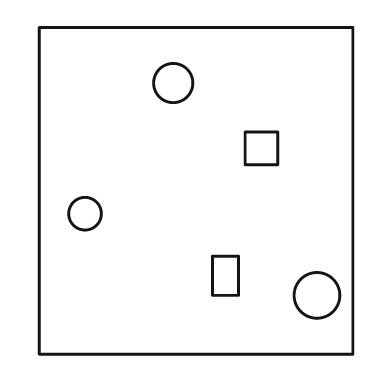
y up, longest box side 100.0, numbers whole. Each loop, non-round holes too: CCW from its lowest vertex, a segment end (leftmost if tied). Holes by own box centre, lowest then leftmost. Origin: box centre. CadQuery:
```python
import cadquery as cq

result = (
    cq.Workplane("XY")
    .moveTo(-48.0, -50.0)
    .lineTo(48.0, -50.0)
    .lineTo(48.0, 50.0)
    .lineTo(-48.0, 50.0)
    .close()
    .moveTo(37.0, -32.0)
    .circle(7.0)
    .moveTo(5.0, -32.0)
    .lineTo(13.0, -32.0)
    .lineTo(13.0, -20.0)
    .lineTo(5.0, -20.0)
    .close()
    .moveTo(-34.0, -7.0)
    .circle(5.0)
    .moveTo(15.0, 8.0)
    .lineTo(25.0, 8.0)
    .lineTo(25.0, 18.0)
    .lineTo(15.0, 18.0)
    .close()
    .moveTo(-7.0, 33.0)
    .circle(6.0)
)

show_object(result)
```